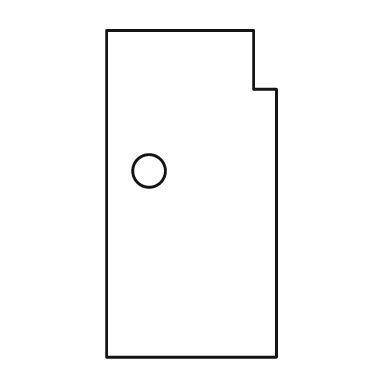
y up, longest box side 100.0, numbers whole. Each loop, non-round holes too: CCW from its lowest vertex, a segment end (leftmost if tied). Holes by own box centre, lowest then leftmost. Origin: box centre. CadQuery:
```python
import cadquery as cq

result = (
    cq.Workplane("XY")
    .moveTo(-26.0, -50.0)
    .lineTo(26.0, -50.0)
    .lineTo(26.0, 32.0)
    .lineTo(19.0, 32.0)
    .lineTo(19.0, 50.0)
    .lineTo(-26.0, 50.0)
    .close()
    .moveTo(-13.0, 7.0)
    .circle(5.0)
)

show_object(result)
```